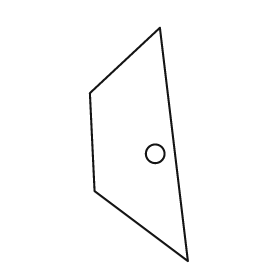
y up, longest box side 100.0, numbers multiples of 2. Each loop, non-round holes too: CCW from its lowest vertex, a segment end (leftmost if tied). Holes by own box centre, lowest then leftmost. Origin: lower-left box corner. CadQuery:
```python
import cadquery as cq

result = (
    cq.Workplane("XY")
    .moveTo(42.0, 0.0)
    .lineTo(30.0, 100.0)
    .lineTo(0.0, 72.0)
    .lineTo(2.0, 30.0)
    .close()
    .moveTo(28.0, 46.0)
    .circle(4.0)
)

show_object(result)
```